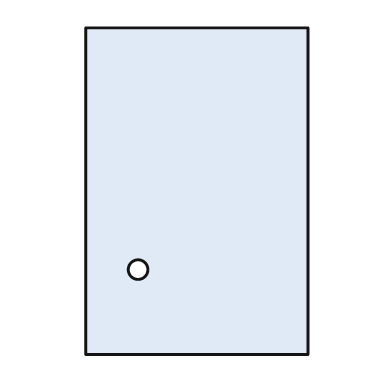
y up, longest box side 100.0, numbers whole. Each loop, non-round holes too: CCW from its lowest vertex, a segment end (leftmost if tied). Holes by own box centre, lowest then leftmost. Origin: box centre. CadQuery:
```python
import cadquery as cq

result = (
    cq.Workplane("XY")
    .moveTo(-34.0, -50.0)
    .lineTo(34.0, -50.0)
    .lineTo(34.0, 50.0)
    .lineTo(-34.0, 50.0)
    .close()
    .moveTo(-18.0, -24.0)
    .circle(3.0)
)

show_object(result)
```